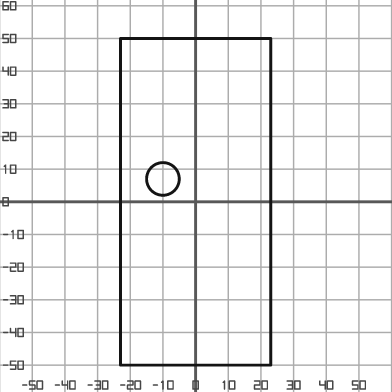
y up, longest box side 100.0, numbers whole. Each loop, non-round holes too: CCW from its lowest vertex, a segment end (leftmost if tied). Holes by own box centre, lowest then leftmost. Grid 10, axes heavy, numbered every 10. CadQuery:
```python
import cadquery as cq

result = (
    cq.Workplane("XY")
    .moveTo(-23.0, -50.0)
    .lineTo(23.0, -50.0)
    .lineTo(23.0, 50.0)
    .lineTo(-23.0, 50.0)
    .close()
    .moveTo(-10.0, 7.0)
    .circle(5.0)
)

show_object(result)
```